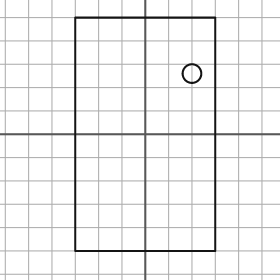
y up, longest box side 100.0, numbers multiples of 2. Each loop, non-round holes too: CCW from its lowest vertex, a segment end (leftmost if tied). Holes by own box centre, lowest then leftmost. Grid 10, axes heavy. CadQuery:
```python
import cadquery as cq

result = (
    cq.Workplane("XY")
    .moveTo(-30.0, -50.0)
    .lineTo(30.0, -50.0)
    .lineTo(30.0, 50.0)
    .lineTo(-30.0, 50.0)
    .close()
    .moveTo(20.0, 26.0)
    .circle(4.0)
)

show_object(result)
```